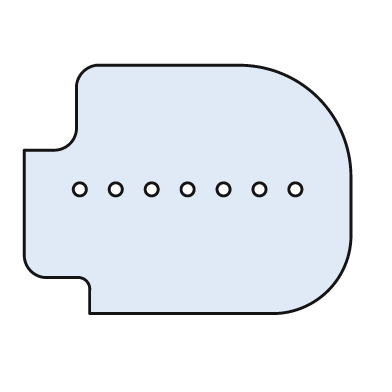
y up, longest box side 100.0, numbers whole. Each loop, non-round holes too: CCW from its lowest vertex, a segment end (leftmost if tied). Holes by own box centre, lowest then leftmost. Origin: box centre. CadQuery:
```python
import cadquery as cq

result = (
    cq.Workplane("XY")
    .moveTo(-30.0, -38.0)
    .lineTo(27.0, -38.0)
    .threePointArc((43.0, -31.0), (50.0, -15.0))
    .lineTo(50.0, 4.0)
    .threePointArc((40.0, 28.0), (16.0, 38.0))
    .lineTo(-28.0, 38.0)
    .threePointArc((-32.0, 36.0), (-34.0, 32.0))
    .lineTo(-34.0, 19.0)
    .threePointArc((-36.0, 14.0), (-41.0, 12.0))
    .lineTo(-50.0, 12.0)
    .lineTo(-50.0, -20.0)
    .threePointArc((-48.0, -25.0), (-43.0, -27.0))
    .lineTo(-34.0, -27.0)
    .threePointArc((-31.0, -28.0), (-30.0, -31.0))
    .close()
    .moveTo(-33.0, 0.0)
    .circle(2.0)
    .moveTo(-22.0, 0.0)
    .circle(2.0)
    .moveTo(-11.0, 0.0)
    .circle(2.0)
    .moveTo(0.0, 0.0)
    .circle(2.0)
    .moveTo(11.0, 0.0)
    .circle(2.0)
    .moveTo(22.0, 0.0)
    .circle(2.0)
    .moveTo(33.0, 0.0)
    .circle(2.0)
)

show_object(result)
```